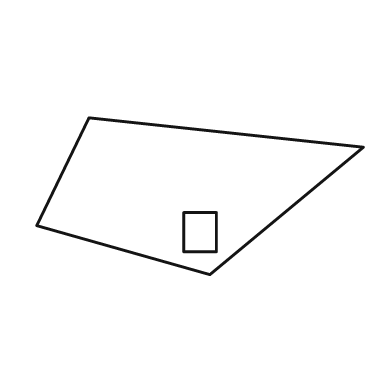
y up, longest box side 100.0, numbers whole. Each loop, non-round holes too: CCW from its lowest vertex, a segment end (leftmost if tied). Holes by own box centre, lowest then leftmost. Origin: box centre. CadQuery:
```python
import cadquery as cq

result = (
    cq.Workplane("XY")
    .moveTo(3.0, -24.0)
    .lineTo(50.0, 15.0)
    .lineTo(-34.0, 24.0)
    .lineTo(-50.0, -9.0)
    .close()
    .moveTo(-5.0, -17.0)
    .lineTo(5.0, -17.0)
    .lineTo(5.0, -5.0)
    .lineTo(-5.0, -5.0)
    .close()
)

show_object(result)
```